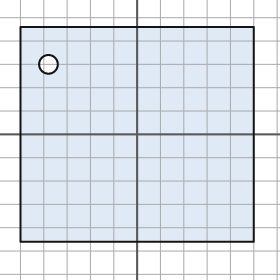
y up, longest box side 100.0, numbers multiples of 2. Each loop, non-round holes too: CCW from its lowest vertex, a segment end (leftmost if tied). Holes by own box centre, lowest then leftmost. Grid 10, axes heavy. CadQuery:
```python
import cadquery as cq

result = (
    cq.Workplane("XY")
    .moveTo(-50.0, -46.0)
    .lineTo(50.0, -46.0)
    .lineTo(50.0, 46.0)
    .lineTo(-50.0, 46.0)
    .close()
    .moveTo(-38.0, 30.0)
    .circle(4.0)
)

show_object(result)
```